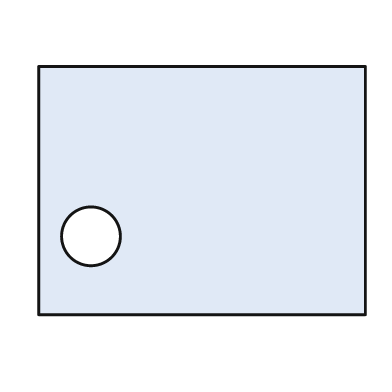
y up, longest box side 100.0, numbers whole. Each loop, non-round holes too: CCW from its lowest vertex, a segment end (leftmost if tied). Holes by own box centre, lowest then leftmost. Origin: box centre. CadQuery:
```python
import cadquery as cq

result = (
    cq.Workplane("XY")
    .moveTo(-50.0, -38.0)
    .lineTo(50.0, -38.0)
    .lineTo(50.0, 38.0)
    .lineTo(-50.0, 38.0)
    .close()
    .moveTo(-34.0, -14.0)
    .circle(9.0)
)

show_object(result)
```